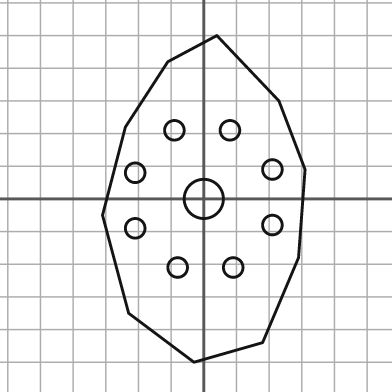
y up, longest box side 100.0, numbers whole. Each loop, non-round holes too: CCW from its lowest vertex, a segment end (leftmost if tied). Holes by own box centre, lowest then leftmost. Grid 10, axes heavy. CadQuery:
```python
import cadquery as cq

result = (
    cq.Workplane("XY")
    .moveTo(-3.0, -50.0)
    .lineTo(18.0, -44.0)
    .lineTo(29.0, -18.0)
    .lineTo(31.0, 9.0)
    .lineTo(23.0, 30.0)
    .lineTo(4.0, 50.0)
    .lineTo(-11.0, 42.0)
    .lineTo(-24.0, 22.0)
    .lineTo(-31.0, -5.0)
    .lineTo(-23.0, -35.0)
    .close()
    .moveTo(-8.0, -21.0)
    .circle(3.0)
    .moveTo(9.0, -21.0)
    .circle(3.0)
    .moveTo(-21.0, -9.0)
    .circle(3.0)
    .moveTo(21.0, -8.0)
    .circle(3.0)
    .moveTo(0.0, 0.0)
    .circle(6.0)
    .moveTo(-21.0, 8.0)
    .circle(3.0)
    .moveTo(21.0, 9.0)
    .circle(3.0)
    .moveTo(-9.0, 21.0)
    .circle(3.0)
    .moveTo(8.0, 21.0)
    .circle(3.0)
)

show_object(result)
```